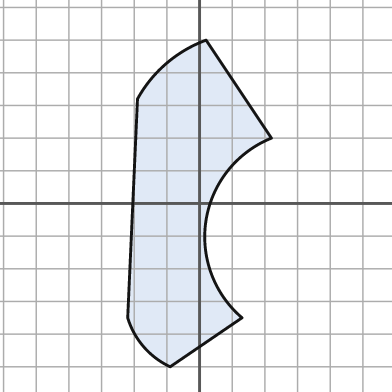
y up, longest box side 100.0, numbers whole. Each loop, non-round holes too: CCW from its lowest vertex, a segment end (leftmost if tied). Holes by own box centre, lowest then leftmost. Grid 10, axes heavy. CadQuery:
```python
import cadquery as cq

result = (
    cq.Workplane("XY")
    .moveTo(-9.0, -50.0)
    .lineTo(13.0, -35.0)
    .threePointArc((2.0, -5.0), (22.0, 20.0))
    .lineTo(2.0, 50.0)
    .threePointArc((-10.0, 43.0), (-19.0, 32.0))
    .lineTo(-22.0, -35.0)
    .threePointArc((-17.0, -44.0), (-9.0, -50.0))
    .close()
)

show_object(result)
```